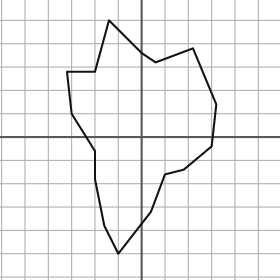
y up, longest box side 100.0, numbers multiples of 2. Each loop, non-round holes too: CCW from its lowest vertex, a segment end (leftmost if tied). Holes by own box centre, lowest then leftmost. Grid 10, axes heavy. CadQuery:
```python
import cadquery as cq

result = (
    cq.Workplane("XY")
    .moveTo(-10.0, -50.0)
    .lineTo(4.0, -32.0)
    .lineTo(10.0, -16.0)
    .lineTo(18.0, -14.0)
    .lineTo(30.0, -4.0)
    .lineTo(32.0, 14.0)
    .lineTo(22.0, 38.0)
    .lineTo(6.0, 32.0)
    .lineTo(0.0, 36.0)
    .lineTo(-14.0, 50.0)
    .lineTo(-20.0, 28.0)
    .lineTo(-32.0, 28.0)
    .lineTo(-30.0, 10.0)
    .lineTo(-20.0, -6.0)
    .lineTo(-20.0, -18.0)
    .lineTo(-16.0, -38.0)
    .close()
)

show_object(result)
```